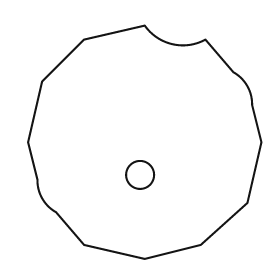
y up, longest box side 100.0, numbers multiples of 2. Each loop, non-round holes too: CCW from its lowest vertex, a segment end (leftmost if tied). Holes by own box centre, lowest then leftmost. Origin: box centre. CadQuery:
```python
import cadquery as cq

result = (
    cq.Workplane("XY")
    .moveTo(0.0, -50.0)
    .lineTo(24.0, -44.0)
    .lineTo(44.0, -26.0)
    .lineTo(50.0, 0.0)
    .lineTo(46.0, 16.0)
    .threePointArc((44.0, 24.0), (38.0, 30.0))
    .lineTo(26.0, 44.0)
    .threePointArc((12.0, 42.0), (0.0, 50.0))
    .lineTo(-26.0, 44.0)
    .lineTo(-44.0, 26.0)
    .lineTo(-50.0, 0.0)
    .lineTo(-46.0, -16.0)
    .threePointArc((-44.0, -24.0), (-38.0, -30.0))
    .lineTo(-26.0, -44.0)
    .close()
    .moveTo(-2.0, -14.0)
    .circle(6.0)
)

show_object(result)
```